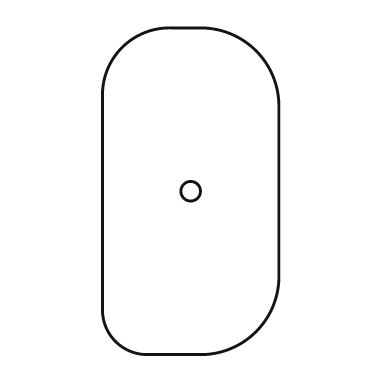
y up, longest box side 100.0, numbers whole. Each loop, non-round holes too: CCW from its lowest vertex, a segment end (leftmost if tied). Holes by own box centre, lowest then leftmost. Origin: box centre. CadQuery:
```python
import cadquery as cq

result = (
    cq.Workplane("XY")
    .moveTo(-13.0, -50.0)
    .lineTo(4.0, -50.0)
    .threePointArc((20.0, -43.0), (27.0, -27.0))
    .lineTo(27.0, 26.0)
    .threePointArc((20.0, 43.0), (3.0, 50.0))
    .lineTo(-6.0, 50.0)
    .threePointArc((-21.0, 44.0), (-27.0, 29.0))
    .lineTo(-27.0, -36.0)
    .threePointArc((-23.0, -46.0), (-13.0, -50.0))
    .close()
    .moveTo(0.0, 0.0)
    .circle(3.0)
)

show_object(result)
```